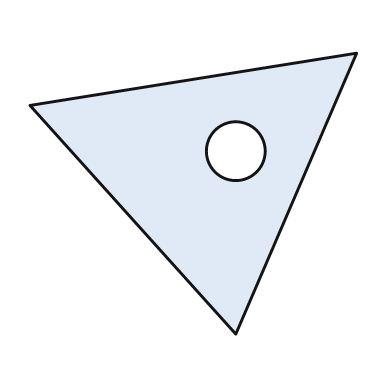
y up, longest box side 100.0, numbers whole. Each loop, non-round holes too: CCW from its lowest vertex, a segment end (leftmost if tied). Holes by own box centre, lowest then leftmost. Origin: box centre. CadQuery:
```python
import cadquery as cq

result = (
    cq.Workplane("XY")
    .moveTo(13.0, -43.0)
    .lineTo(50.0, 43.0)
    .lineTo(-50.0, 27.0)
    .close()
    .moveTo(13.0, 13.0)
    .circle(9.0)
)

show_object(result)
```